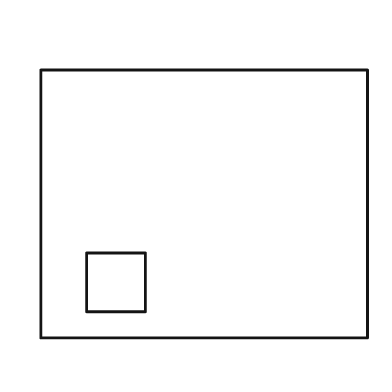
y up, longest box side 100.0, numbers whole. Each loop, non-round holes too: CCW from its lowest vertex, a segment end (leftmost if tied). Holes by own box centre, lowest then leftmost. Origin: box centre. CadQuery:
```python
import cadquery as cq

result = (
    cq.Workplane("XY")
    .moveTo(-50.0, -41.0)
    .lineTo(50.0, -41.0)
    .lineTo(50.0, 41.0)
    .lineTo(-50.0, 41.0)
    .close()
    .moveTo(-36.0, -33.0)
    .lineTo(-18.0, -33.0)
    .lineTo(-18.0, -15.0)
    .lineTo(-36.0, -15.0)
    .close()
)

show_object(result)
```